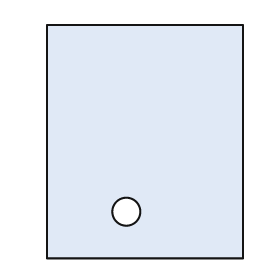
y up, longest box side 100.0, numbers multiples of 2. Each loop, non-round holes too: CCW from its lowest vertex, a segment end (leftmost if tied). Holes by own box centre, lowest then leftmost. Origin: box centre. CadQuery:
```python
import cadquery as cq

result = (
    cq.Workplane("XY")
    .moveTo(-42.0, -50.0)
    .lineTo(42.0, -50.0)
    .lineTo(42.0, 50.0)
    .lineTo(-42.0, 50.0)
    .close()
    .moveTo(-8.0, -30.0)
    .circle(6.0)
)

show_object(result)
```